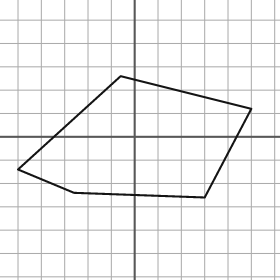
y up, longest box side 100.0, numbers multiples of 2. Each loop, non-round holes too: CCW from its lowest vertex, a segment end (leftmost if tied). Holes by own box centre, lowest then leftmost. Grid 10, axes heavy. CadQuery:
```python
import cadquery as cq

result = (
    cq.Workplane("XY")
    .moveTo(30.0, -26.0)
    .lineTo(50.0, 12.0)
    .lineTo(-6.0, 26.0)
    .lineTo(-50.0, -14.0)
    .lineTo(-26.0, -24.0)
    .close()
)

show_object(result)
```